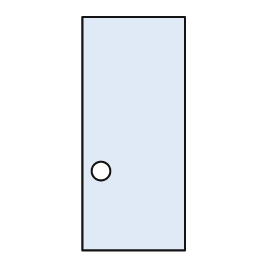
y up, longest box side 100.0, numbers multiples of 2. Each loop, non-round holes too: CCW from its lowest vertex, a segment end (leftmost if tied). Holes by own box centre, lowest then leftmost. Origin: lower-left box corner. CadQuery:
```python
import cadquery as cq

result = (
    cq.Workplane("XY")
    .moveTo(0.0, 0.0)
    .lineTo(44.0, 0.0)
    .lineTo(44.0, 100.0)
    .lineTo(0.0, 100.0)
    .close()
    .moveTo(8.0, 34.0)
    .circle(4.0)
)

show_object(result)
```